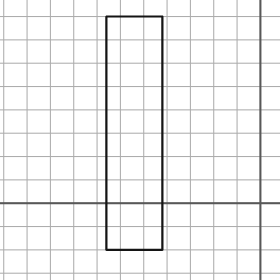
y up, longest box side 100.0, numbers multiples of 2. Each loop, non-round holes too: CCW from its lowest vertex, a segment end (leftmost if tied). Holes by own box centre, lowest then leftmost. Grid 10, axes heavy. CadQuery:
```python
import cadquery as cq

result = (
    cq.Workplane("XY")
    .moveTo(-66.0, -20.0)
    .lineTo(-42.0, -20.0)
    .lineTo(-42.0, 80.0)
    .lineTo(-66.0, 80.0)
    .close()
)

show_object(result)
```